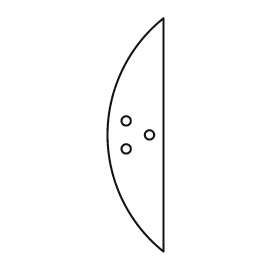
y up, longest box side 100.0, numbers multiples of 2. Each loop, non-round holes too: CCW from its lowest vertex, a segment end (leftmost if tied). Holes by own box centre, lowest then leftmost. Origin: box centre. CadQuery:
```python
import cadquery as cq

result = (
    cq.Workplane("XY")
    .moveTo(12.0, -50.0)
    .lineTo(12.0, 50.0)
    .threePointArc((-12.0, 0.0), (12.0, -50.0))
    .close()
    .moveTo(-4.0, -6.0)
    .circle(2.0)
    .moveTo(6.0, 0.0)
    .circle(2.0)
    .moveTo(-4.0, 6.0)
    .circle(2.0)
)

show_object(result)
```